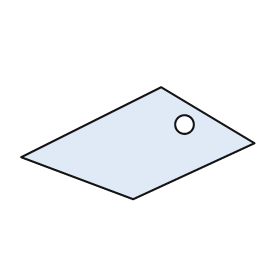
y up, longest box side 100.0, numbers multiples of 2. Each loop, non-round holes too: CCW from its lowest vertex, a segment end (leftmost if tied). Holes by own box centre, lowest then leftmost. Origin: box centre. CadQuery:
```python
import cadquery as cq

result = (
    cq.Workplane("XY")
    .moveTo(-2.0, -24.0)
    .lineTo(50.0, 0.0)
    .lineTo(10.0, 24.0)
    .lineTo(-50.0, -6.0)
    .close()
    .moveTo(20.0, 8.0)
    .circle(4.0)
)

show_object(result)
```